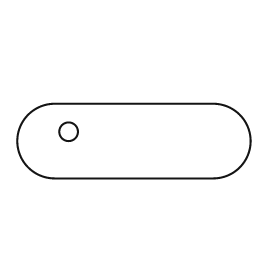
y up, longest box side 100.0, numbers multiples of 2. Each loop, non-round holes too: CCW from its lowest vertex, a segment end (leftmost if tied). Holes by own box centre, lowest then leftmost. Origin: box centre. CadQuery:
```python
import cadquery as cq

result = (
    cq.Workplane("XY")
    .moveTo(-34.0, -16.0)
    .lineTo(34.0, -16.0)
    .threePointArc((50.0, 0.0), (34.0, 16.0))
    .lineTo(-34.0, 16.0)
    .threePointArc((-50.0, 0.0), (-34.0, -16.0))
    .close()
    .moveTo(-28.0, 4.0)
    .circle(4.0)
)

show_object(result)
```